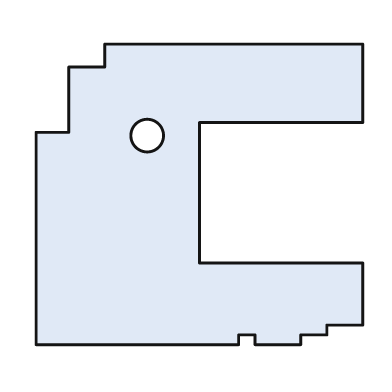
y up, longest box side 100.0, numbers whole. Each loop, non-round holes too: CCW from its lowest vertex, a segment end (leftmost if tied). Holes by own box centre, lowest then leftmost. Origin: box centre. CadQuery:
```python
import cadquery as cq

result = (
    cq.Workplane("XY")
    .moveTo(-50.0, -46.0)
    .lineTo(12.0, -46.0)
    .lineTo(12.0, -43.0)
    .lineTo(17.0, -43.0)
    .lineTo(17.0, -46.0)
    .lineTo(31.0, -46.0)
    .lineTo(31.0, -43.0)
    .lineTo(39.0, -43.0)
    .lineTo(39.0, -40.0)
    .lineTo(50.0, -40.0)
    .lineTo(50.0, -21.0)
    .lineTo(0.0, -21.0)
    .lineTo(0.0, 22.0)
    .lineTo(50.0, 22.0)
    .lineTo(50.0, 46.0)
    .lineTo(-29.0, 46.0)
    .lineTo(-29.0, 39.0)
    .lineTo(-40.0, 39.0)
    .lineTo(-40.0, 19.0)
    .lineTo(-50.0, 19.0)
    .close()
    .moveTo(-16.0, 18.0)
    .circle(5.0)
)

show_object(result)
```